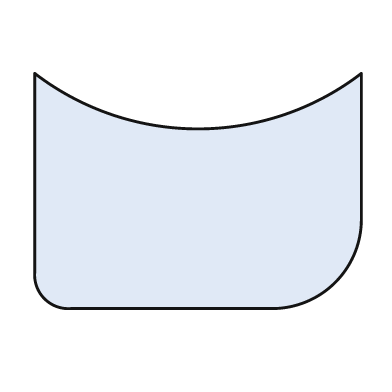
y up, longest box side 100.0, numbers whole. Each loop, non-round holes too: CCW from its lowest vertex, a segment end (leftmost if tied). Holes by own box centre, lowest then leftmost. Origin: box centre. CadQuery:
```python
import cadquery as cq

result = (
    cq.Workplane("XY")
    .moveTo(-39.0, -36.0)
    .lineTo(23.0, -36.0)
    .threePointArc((42.0, -28.0), (50.0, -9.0))
    .lineTo(50.0, 36.0)
    .threePointArc((0.0, 19.0), (-50.0, 36.0))
    .lineTo(-50.0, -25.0)
    .threePointArc((-47.0, -33.0), (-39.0, -36.0))
    .close()
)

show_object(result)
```